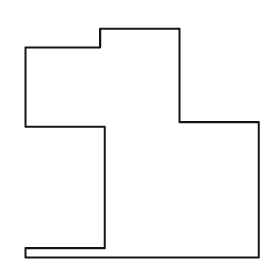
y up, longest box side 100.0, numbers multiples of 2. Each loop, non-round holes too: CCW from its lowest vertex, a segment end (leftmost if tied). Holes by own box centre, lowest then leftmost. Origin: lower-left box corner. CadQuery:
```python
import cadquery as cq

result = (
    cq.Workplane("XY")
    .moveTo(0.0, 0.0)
    .lineTo(100.0, 0.0)
    .lineTo(100.0, 58.0)
    .lineTo(66.0, 58.0)
    .lineTo(66.0, 98.0)
    .lineTo(32.0, 98.0)
    .lineTo(32.0, 90.0)
    .lineTo(0.0, 90.0)
    .lineTo(0.0, 56.0)
    .lineTo(34.0, 56.0)
    .lineTo(34.0, 4.0)
    .lineTo(0.0, 4.0)
    .close()
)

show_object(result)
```